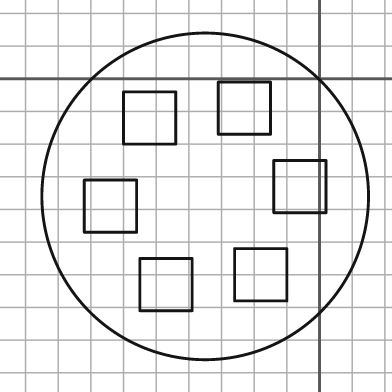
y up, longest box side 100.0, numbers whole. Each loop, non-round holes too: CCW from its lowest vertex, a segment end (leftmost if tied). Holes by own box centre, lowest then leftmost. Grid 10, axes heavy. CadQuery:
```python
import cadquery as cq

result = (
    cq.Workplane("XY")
    .moveTo(-35.0, -36.0)
    .circle(50.0)
    .moveTo(-55.0, -71.0)
    .lineTo(-39.0, -71.0)
    .lineTo(-39.0, -55.0)
    .lineTo(-55.0, -55.0)
    .close()
    .moveTo(-26.0, -68.0)
    .lineTo(-10.0, -68.0)
    .lineTo(-10.0, -52.0)
    .lineTo(-26.0, -52.0)
    .close()
    .moveTo(-72.0, -47.0)
    .lineTo(-56.0, -47.0)
    .lineTo(-56.0, -31.0)
    .lineTo(-72.0, -31.0)
    .close()
    .moveTo(-14.0, -41.0)
    .lineTo(2.0, -41.0)
    .lineTo(2.0, -25.0)
    .lineTo(-14.0, -25.0)
    .close()
    .moveTo(-60.0, -20.0)
    .lineTo(-44.0, -20.0)
    .lineTo(-44.0, -4.0)
    .lineTo(-60.0, -4.0)
    .close()
    .moveTo(-31.0, -17.0)
    .lineTo(-15.0, -17.0)
    .lineTo(-15.0, -1.0)
    .lineTo(-31.0, -1.0)
    .close()
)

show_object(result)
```